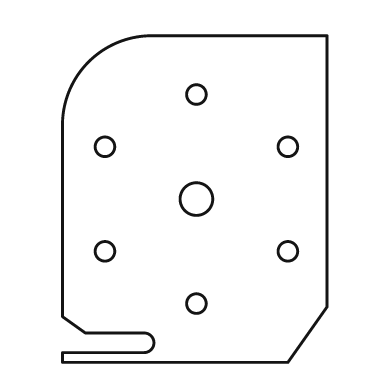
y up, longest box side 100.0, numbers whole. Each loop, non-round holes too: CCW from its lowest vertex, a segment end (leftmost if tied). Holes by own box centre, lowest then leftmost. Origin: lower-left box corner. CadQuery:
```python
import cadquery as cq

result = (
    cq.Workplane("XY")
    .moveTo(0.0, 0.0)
    .lineTo(69.0, 0.0)
    .lineTo(81.0, 17.0)
    .lineTo(81.0, 100.0)
    .lineTo(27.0, 100.0)
    .threePointArc((8.0, 92.0), (0.0, 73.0))
    .lineTo(0.0, 14.0)
    .lineTo(7.0, 9.0)
    .lineTo(25.0, 9.0)
    .threePointArc((28.0, 6.0), (25.0, 3.0))
    .lineTo(0.0, 3.0)
    .close()
    .moveTo(41.0, 18.0)
    .circle(3.0)
    .moveTo(13.0, 34.0)
    .circle(3.0)
    .moveTo(69.0, 34.0)
    .circle(3.0)
    .moveTo(41.0, 50.0)
    .circle(5.0)
    .moveTo(13.0, 66.0)
    .circle(3.0)
    .moveTo(69.0, 66.0)
    .circle(3.0)
    .moveTo(41.0, 82.0)
    .circle(3.0)
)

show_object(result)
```